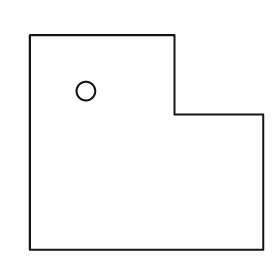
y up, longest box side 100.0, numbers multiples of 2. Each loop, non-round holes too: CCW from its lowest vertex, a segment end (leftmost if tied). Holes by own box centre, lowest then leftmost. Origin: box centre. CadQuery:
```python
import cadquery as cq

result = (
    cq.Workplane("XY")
    .moveTo(-50.0, -46.0)
    .lineTo(50.0, -46.0)
    .lineTo(50.0, 12.0)
    .lineTo(12.0, 12.0)
    .lineTo(12.0, 46.0)
    .lineTo(-50.0, 46.0)
    .close()
    .moveTo(-26.0, 22.0)
    .circle(4.0)
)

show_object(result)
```